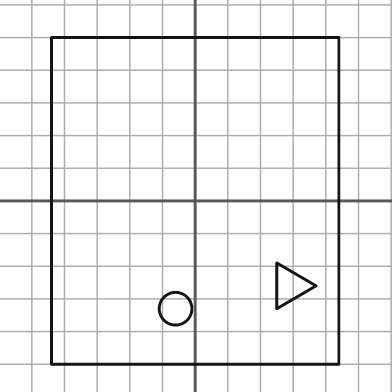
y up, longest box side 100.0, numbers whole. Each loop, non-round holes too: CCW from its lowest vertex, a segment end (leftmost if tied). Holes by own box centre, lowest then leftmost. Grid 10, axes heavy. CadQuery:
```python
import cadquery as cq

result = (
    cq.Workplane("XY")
    .moveTo(-44.0, -50.0)
    .lineTo(44.0, -50.0)
    .lineTo(44.0, 50.0)
    .lineTo(-44.0, 50.0)
    .close()
    .moveTo(-6.0, -33.0)
    .circle(5.0)
    .moveTo(25.0, -33.0)
    .lineTo(37.0, -26.0)
    .lineTo(25.0, -19.0)
    .close()
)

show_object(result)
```